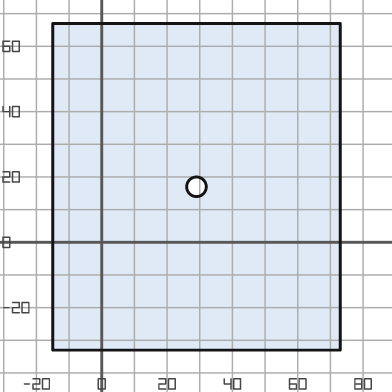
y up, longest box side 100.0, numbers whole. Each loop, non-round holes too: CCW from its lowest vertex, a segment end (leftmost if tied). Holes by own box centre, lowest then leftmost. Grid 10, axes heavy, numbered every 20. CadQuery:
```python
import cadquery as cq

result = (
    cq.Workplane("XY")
    .moveTo(-15.0, -33.0)
    .lineTo(73.0, -33.0)
    .lineTo(73.0, 67.0)
    .lineTo(-15.0, 67.0)
    .close()
    .moveTo(29.0, 17.0)
    .circle(3.0)
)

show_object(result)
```